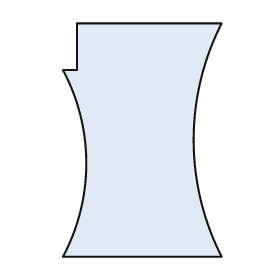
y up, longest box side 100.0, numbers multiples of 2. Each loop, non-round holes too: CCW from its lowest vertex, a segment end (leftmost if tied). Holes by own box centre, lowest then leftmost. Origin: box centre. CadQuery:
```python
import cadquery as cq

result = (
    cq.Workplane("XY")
    .moveTo(-34.0, -50.0)
    .lineTo(34.0, -50.0)
    .threePointArc((22.0, 0.0), (34.0, 50.0))
    .lineTo(-28.0, 50.0)
    .lineTo(-28.0, 30.0)
    .lineTo(-34.0, 30.0)
    .threePointArc((-24.0, -10.0), (-34.0, -50.0))
    .close()
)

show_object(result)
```